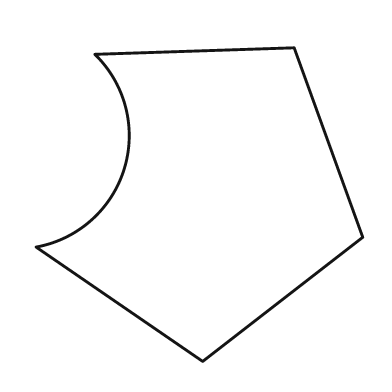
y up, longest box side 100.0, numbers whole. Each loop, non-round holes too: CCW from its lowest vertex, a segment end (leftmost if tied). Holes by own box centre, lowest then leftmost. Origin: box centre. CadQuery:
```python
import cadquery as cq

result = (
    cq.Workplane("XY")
    .moveTo(1.0, -48.0)
    .lineTo(50.0, -10.0)
    .lineTo(29.0, 48.0)
    .lineTo(-32.0, 46.0)
    .threePointArc((-23.0, 11.0), (-50.0, -13.0))
    .close()
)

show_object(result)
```